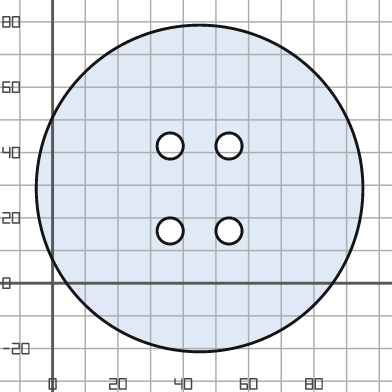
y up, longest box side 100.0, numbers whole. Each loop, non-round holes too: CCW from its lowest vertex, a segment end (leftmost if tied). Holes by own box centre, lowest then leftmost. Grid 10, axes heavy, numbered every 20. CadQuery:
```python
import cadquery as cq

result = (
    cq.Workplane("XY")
    .moveTo(45.0, 29.0)
    .circle(50.0)
    .moveTo(36.0, 16.0)
    .circle(4.0)
    .moveTo(54.0, 16.0)
    .circle(4.0)
    .moveTo(36.0, 42.0)
    .circle(4.0)
    .moveTo(54.0, 42.0)
    .circle(4.0)
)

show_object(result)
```